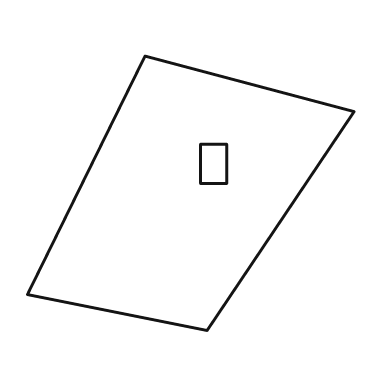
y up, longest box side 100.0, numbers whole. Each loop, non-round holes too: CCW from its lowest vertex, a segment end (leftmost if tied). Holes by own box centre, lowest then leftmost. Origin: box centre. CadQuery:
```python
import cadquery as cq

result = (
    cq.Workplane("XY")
    .moveTo(5.0, -42.0)
    .lineTo(50.0, 25.0)
    .lineTo(-14.0, 42.0)
    .lineTo(-50.0, -31.0)
    .close()
    .moveTo(3.0, 3.0)
    .lineTo(11.0, 3.0)
    .lineTo(11.0, 15.0)
    .lineTo(3.0, 15.0)
    .close()
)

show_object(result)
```